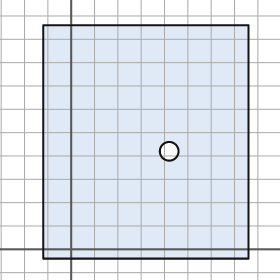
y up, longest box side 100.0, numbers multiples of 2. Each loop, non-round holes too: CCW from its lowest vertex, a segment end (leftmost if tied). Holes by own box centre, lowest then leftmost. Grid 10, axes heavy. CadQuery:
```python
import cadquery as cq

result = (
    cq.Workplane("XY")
    .moveTo(-12.0, -4.0)
    .lineTo(76.0, -4.0)
    .lineTo(76.0, 96.0)
    .lineTo(-12.0, 96.0)
    .close()
    .moveTo(42.0, 42.0)
    .circle(4.0)
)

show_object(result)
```